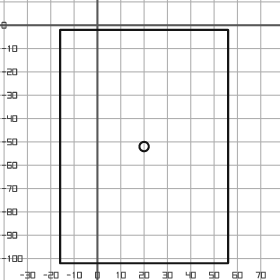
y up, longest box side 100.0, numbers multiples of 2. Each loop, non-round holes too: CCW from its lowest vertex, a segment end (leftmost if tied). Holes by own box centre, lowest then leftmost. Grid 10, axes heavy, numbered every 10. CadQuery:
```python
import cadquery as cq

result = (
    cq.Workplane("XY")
    .moveTo(-16.0, -102.0)
    .lineTo(56.0, -102.0)
    .lineTo(56.0, -2.0)
    .lineTo(-16.0, -2.0)
    .close()
    .moveTo(20.0, -52.0)
    .circle(2.0)
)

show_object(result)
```